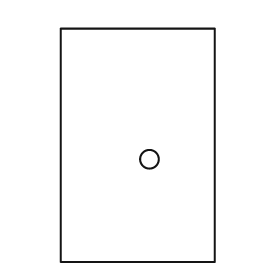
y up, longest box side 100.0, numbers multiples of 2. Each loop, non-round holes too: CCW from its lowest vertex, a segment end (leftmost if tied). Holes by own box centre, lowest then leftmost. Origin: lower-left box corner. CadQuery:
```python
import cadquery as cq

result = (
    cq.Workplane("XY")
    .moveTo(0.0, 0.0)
    .lineTo(66.0, 0.0)
    .lineTo(66.0, 100.0)
    .lineTo(0.0, 100.0)
    .close()
    .moveTo(38.0, 44.0)
    .circle(4.0)
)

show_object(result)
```